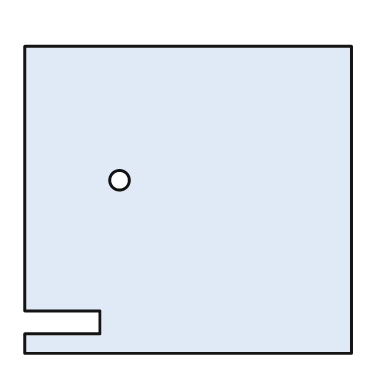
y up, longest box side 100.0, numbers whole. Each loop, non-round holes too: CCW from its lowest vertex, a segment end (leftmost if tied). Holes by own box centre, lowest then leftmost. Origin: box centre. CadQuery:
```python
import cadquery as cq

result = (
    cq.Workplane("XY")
    .moveTo(-50.0, -47.0)
    .lineTo(50.0, -47.0)
    .lineTo(50.0, 47.0)
    .lineTo(-50.0, 47.0)
    .lineTo(-50.0, -34.0)
    .lineTo(-27.0, -34.0)
    .lineTo(-27.0, -41.0)
    .lineTo(-50.0, -41.0)
    .close()
    .moveTo(-21.0, 6.0)
    .circle(3.0)
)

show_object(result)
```